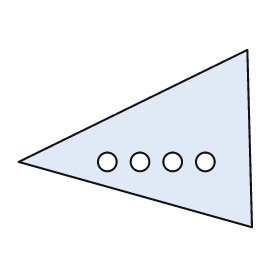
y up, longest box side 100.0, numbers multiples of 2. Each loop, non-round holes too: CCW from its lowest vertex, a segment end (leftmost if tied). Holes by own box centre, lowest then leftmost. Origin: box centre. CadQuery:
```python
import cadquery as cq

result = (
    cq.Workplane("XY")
    .moveTo(50.0, -38.0)
    .lineTo(48.0, 38.0)
    .lineTo(-50.0, -10.0)
    .close()
    .moveTo(-12.0, -10.0)
    .circle(4.0)
    .moveTo(2.0, -10.0)
    .circle(4.0)
    .moveTo(16.0, -10.0)
    .circle(4.0)
    .moveTo(30.0, -10.0)
    .circle(4.0)
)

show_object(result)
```